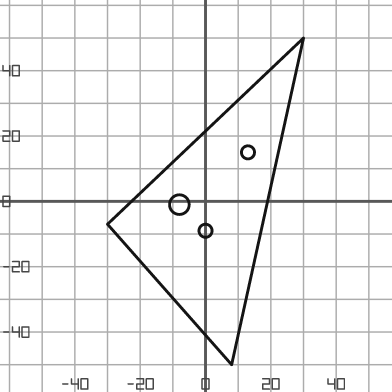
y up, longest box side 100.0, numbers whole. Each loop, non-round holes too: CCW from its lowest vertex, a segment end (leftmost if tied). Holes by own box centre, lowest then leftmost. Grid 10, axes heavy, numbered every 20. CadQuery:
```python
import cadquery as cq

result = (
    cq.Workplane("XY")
    .moveTo(8.0, -50.0)
    .lineTo(30.0, 50.0)
    .lineTo(-30.0, -7.0)
    .close()
    .moveTo(0.0, -9.0)
    .circle(2.0)
    .moveTo(-8.0, -1.0)
    .circle(3.0)
    .moveTo(13.0, 15.0)
    .circle(2.0)
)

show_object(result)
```